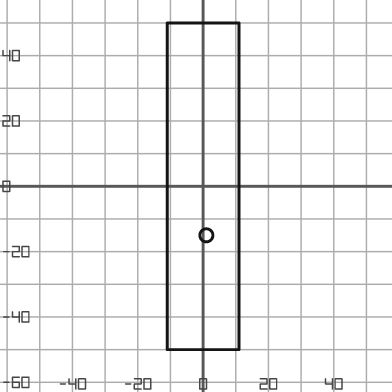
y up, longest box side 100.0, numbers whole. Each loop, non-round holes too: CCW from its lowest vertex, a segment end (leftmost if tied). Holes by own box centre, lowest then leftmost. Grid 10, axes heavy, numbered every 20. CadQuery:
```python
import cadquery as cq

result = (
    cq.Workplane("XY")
    .moveTo(-11.0, -50.0)
    .lineTo(11.0, -50.0)
    .lineTo(11.0, 50.0)
    .lineTo(-11.0, 50.0)
    .close()
    .moveTo(1.0, -15.0)
    .circle(2.0)
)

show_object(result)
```